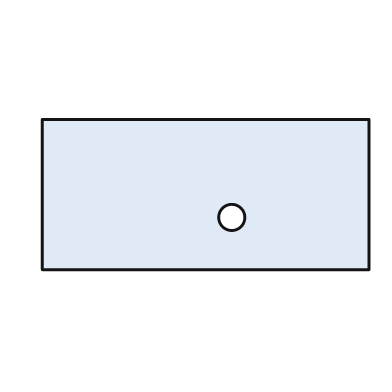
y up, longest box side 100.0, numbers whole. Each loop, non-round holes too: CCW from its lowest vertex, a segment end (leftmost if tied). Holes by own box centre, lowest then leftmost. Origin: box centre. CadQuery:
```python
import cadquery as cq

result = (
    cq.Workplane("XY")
    .moveTo(-50.0, -23.0)
    .lineTo(50.0, -23.0)
    .lineTo(50.0, 23.0)
    .lineTo(-50.0, 23.0)
    .close()
    .moveTo(8.0, -7.0)
    .circle(4.0)
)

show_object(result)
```